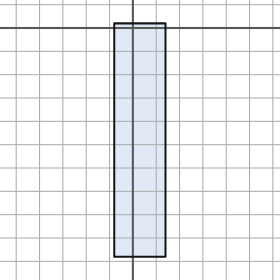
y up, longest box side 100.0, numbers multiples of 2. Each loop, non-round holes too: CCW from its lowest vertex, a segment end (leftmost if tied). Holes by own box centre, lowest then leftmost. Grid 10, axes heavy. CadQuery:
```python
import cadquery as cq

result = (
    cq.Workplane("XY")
    .moveTo(-8.0, -98.0)
    .lineTo(14.0, -98.0)
    .lineTo(14.0, 2.0)
    .lineTo(-8.0, 2.0)
    .close()
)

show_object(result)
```